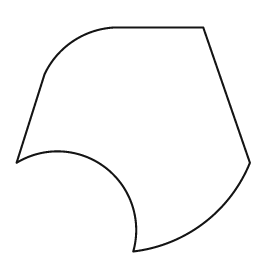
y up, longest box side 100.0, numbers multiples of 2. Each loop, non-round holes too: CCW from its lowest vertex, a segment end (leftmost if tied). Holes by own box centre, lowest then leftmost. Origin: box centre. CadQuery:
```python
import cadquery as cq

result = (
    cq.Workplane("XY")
    .moveTo(0.0, -48.0)
    .threePointArc((30.0, -36.0), (50.0, -10.0))
    .lineTo(30.0, 48.0)
    .lineTo(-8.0, 48.0)
    .threePointArc((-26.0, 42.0), (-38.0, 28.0))
    .lineTo(-50.0, -10.0)
    .threePointArc((-12.0, -12.0), (0.0, -48.0))
    .close()
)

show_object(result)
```